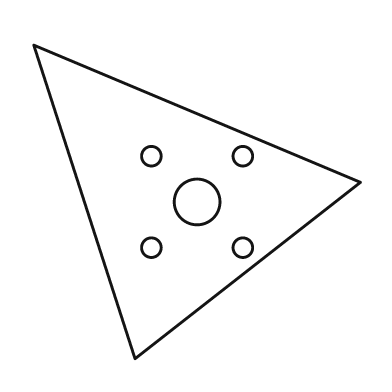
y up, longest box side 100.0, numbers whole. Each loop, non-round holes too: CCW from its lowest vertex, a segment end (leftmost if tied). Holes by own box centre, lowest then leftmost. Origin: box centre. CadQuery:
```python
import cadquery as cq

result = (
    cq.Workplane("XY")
    .moveTo(-19.0, -48.0)
    .lineTo(50.0, 6.0)
    .lineTo(-50.0, 48.0)
    .close()
    .moveTo(-14.0, -14.0)
    .circle(3.0)
    .moveTo(14.0, -14.0)
    .circle(3.0)
    .moveTo(0.0, 0.0)
    .circle(7.0)
    .moveTo(-14.0, 14.0)
    .circle(3.0)
    .moveTo(14.0, 14.0)
    .circle(3.0)
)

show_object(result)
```